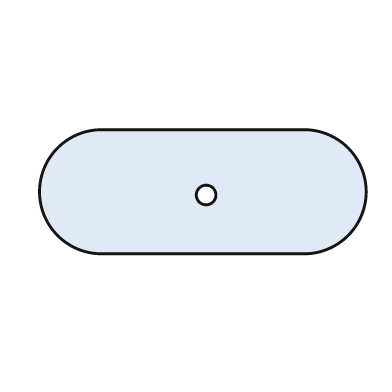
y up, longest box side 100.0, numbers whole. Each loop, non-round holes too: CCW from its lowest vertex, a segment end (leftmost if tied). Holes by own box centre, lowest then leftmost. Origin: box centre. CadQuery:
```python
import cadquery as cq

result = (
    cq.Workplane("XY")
    .moveTo(-31.0, -19.0)
    .lineTo(31.0, -19.0)
    .threePointArc((50.0, 0.0), (31.0, 19.0))
    .lineTo(-31.0, 19.0)
    .threePointArc((-50.0, 0.0), (-31.0, -19.0))
    .close()
    .moveTo(1.0, -1.0)
    .circle(3.0)
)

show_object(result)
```